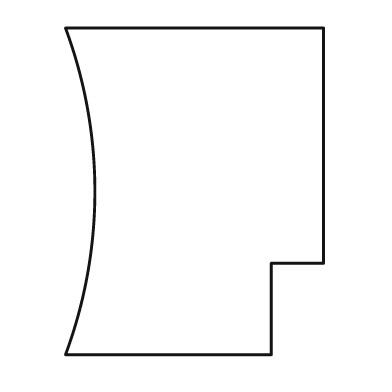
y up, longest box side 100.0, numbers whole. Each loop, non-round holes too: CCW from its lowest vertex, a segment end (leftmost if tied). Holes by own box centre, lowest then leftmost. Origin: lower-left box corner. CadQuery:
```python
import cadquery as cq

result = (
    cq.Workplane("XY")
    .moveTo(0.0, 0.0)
    .lineTo(63.0, 0.0)
    .lineTo(63.0, 28.0)
    .lineTo(79.0, 28.0)
    .lineTo(79.0, 100.0)
    .lineTo(0.0, 100.0)
    .threePointArc((9.0, 50.0), (0.0, 0.0))
    .close()
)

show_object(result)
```